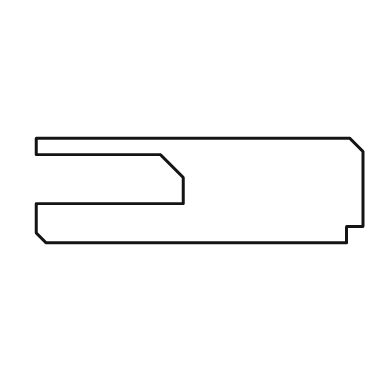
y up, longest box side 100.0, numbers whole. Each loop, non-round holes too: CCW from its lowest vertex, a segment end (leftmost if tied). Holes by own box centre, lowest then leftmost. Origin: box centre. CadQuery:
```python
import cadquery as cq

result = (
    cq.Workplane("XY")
    .moveTo(-47.0, -16.0)
    .lineTo(45.0, -16.0)
    .lineTo(45.0, -11.0)
    .lineTo(50.0, -11.0)
    .lineTo(50.0, 12.0)
    .lineTo(46.0, 16.0)
    .lineTo(-50.0, 16.0)
    .lineTo(-50.0, 11.0)
    .lineTo(-12.0, 11.0)
    .lineTo(-5.0, 4.0)
    .lineTo(-5.0, -4.0)
    .lineTo(-50.0, -4.0)
    .lineTo(-50.0, -13.0)
    .close()
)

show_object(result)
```